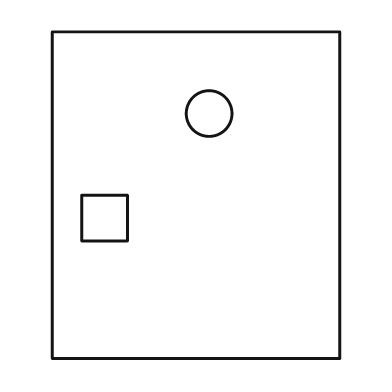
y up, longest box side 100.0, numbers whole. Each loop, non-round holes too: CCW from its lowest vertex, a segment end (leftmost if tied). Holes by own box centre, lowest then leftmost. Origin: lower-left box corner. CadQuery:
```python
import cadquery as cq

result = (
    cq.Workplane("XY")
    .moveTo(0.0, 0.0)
    .lineTo(88.0, 0.0)
    .lineTo(88.0, 100.0)
    .lineTo(0.0, 100.0)
    .close()
    .moveTo(9.0, 36.0)
    .lineTo(23.0, 36.0)
    .lineTo(23.0, 50.0)
    .lineTo(9.0, 50.0)
    .close()
    .moveTo(48.0, 75.0)
    .circle(7.0)
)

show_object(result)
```